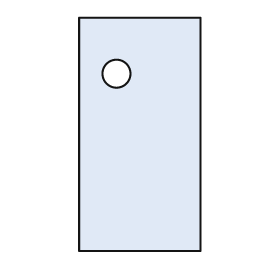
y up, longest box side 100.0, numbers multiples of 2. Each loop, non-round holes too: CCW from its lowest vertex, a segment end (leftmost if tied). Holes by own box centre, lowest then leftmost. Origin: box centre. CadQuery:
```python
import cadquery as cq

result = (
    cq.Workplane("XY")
    .moveTo(-26.0, -50.0)
    .lineTo(26.0, -50.0)
    .lineTo(26.0, 50.0)
    .lineTo(-26.0, 50.0)
    .close()
    .moveTo(-10.0, 26.0)
    .circle(6.0)
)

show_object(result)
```